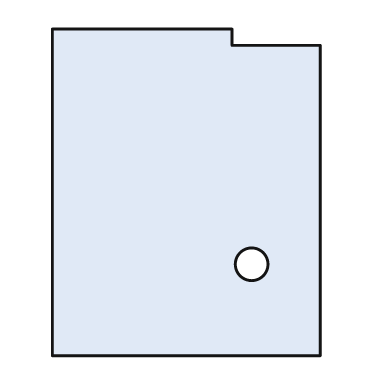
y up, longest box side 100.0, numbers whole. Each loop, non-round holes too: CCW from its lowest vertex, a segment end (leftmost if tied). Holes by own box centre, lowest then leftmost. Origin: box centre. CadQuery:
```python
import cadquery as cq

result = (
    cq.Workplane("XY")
    .moveTo(-41.0, -50.0)
    .lineTo(41.0, -50.0)
    .lineTo(41.0, 45.0)
    .lineTo(14.0, 45.0)
    .lineTo(14.0, 50.0)
    .lineTo(-41.0, 50.0)
    .close()
    .moveTo(20.0, -22.0)
    .circle(5.0)
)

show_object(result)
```